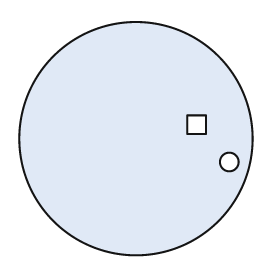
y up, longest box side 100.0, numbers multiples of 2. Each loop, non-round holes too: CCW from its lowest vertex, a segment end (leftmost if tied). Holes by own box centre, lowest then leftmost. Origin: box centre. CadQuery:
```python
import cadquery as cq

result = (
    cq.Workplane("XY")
    .moveTo(0.0, 0.0)
    .circle(50.0)
    .moveTo(40.0, -10.0)
    .circle(4.0)
    .moveTo(22.0, 2.0)
    .lineTo(30.0, 2.0)
    .lineTo(30.0, 10.0)
    .lineTo(22.0, 10.0)
    .close()
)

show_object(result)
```